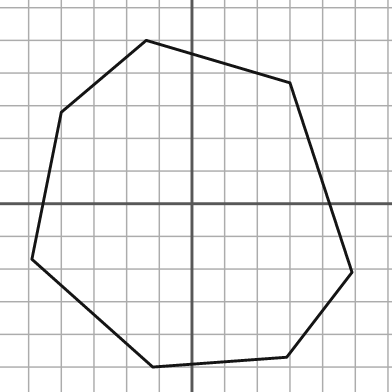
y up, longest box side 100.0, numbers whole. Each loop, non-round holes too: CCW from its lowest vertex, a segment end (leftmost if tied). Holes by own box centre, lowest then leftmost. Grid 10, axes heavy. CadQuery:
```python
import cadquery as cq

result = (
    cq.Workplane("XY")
    .moveTo(-12.0, -50.0)
    .lineTo(29.0, -47.0)
    .lineTo(49.0, -21.0)
    .lineTo(30.0, 37.0)
    .lineTo(-14.0, 50.0)
    .lineTo(-40.0, 28.0)
    .lineTo(-49.0, -17.0)
    .close()
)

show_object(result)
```